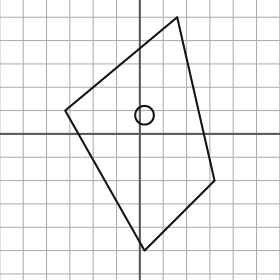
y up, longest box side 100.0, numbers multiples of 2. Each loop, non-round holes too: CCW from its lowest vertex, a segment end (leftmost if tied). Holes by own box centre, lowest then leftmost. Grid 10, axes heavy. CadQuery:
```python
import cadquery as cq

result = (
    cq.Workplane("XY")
    .moveTo(2.0, -50.0)
    .lineTo(32.0, -20.0)
    .lineTo(16.0, 50.0)
    .lineTo(-32.0, 10.0)
    .close()
    .moveTo(2.0, 8.0)
    .circle(4.0)
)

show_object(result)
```